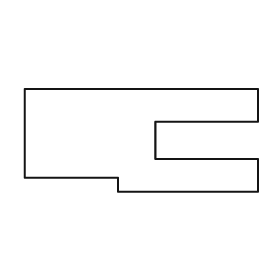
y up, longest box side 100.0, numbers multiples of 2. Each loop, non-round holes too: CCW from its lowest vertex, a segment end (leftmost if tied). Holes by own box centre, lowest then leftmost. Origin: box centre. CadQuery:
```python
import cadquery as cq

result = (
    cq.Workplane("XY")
    .moveTo(-10.0, -22.0)
    .lineTo(50.0, -22.0)
    .lineTo(50.0, -8.0)
    .lineTo(6.0, -8.0)
    .lineTo(6.0, 8.0)
    .lineTo(50.0, 8.0)
    .lineTo(50.0, 22.0)
    .lineTo(-50.0, 22.0)
    .lineTo(-50.0, -16.0)
    .lineTo(-10.0, -16.0)
    .close()
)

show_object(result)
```